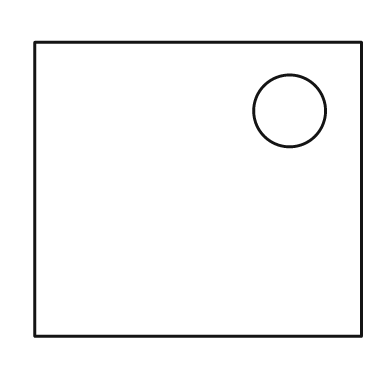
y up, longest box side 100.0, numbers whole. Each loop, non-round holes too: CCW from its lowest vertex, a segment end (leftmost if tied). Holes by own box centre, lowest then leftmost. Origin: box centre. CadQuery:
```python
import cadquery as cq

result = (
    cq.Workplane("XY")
    .moveTo(-50.0, -45.0)
    .lineTo(50.0, -45.0)
    .lineTo(50.0, 45.0)
    .lineTo(-50.0, 45.0)
    .close()
    .moveTo(28.0, 24.0)
    .circle(11.0)
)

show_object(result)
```